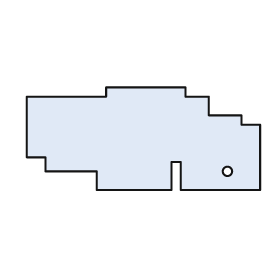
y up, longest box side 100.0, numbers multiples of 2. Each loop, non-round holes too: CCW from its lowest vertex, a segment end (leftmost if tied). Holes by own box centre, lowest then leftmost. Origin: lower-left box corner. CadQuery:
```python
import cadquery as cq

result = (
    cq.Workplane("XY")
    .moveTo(30.0, 0.0)
    .lineTo(62.0, 0.0)
    .lineTo(62.0, 12.0)
    .lineTo(66.0, 12.0)
    .lineTo(66.0, 0.0)
    .lineTo(100.0, 0.0)
    .lineTo(100.0, 28.0)
    .lineTo(92.0, 28.0)
    .lineTo(92.0, 32.0)
    .lineTo(78.0, 32.0)
    .lineTo(78.0, 40.0)
    .lineTo(68.0, 40.0)
    .lineTo(68.0, 44.0)
    .lineTo(34.0, 44.0)
    .lineTo(34.0, 40.0)
    .lineTo(0.0, 40.0)
    .lineTo(0.0, 14.0)
    .lineTo(8.0, 14.0)
    .lineTo(8.0, 8.0)
    .lineTo(30.0, 8.0)
    .close()
    .moveTo(86.0, 8.0)
    .circle(2.0)
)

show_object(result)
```